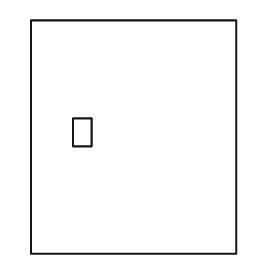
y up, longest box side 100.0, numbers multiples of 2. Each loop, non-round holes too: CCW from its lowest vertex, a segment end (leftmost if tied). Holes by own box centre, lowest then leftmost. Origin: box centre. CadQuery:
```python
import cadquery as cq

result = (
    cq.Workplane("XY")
    .moveTo(-44.0, -50.0)
    .lineTo(44.0, -50.0)
    .lineTo(44.0, 50.0)
    .lineTo(-44.0, 50.0)
    .close()
    .moveTo(-26.0, -4.0)
    .lineTo(-18.0, -4.0)
    .lineTo(-18.0, 8.0)
    .lineTo(-26.0, 8.0)
    .close()
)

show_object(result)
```